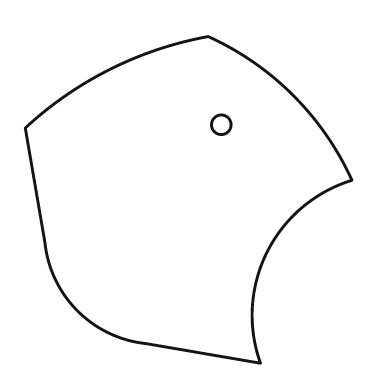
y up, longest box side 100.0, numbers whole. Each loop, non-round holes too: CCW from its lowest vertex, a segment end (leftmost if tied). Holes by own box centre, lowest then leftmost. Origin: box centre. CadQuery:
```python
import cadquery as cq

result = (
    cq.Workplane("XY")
    .moveTo(22.0, -50.0)
    .threePointArc((24.0, -16.0), (50.0, 6.0))
    .threePointArc((32.0, 32.0), (6.0, 50.0))
    .threePointArc((-24.0, 40.0), (-50.0, 22.0))
    .lineTo(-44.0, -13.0)
    .threePointArc((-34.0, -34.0), (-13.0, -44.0))
    .close()
    .moveTo(10.0, 23.0)
    .circle(3.0)
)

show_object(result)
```